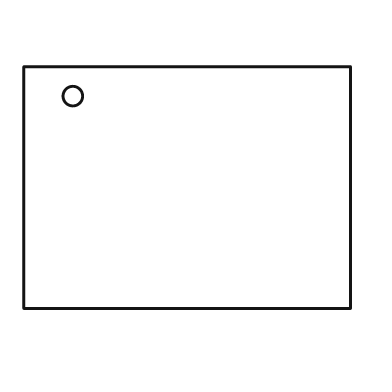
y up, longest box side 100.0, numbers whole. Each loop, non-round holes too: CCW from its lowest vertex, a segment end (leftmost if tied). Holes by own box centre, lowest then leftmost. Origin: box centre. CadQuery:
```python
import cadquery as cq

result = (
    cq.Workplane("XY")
    .moveTo(-50.0, -37.0)
    .lineTo(50.0, -37.0)
    .lineTo(50.0, 37.0)
    .lineTo(-50.0, 37.0)
    .close()
    .moveTo(-35.0, 28.0)
    .circle(3.0)
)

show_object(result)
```